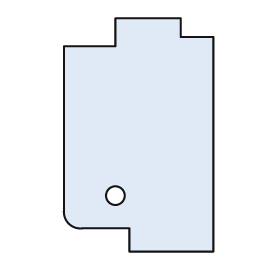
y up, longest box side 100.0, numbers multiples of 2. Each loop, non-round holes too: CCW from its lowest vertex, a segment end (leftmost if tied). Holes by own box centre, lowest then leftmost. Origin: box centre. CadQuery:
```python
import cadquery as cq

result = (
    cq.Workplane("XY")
    .moveTo(-4.0, -50.0)
    .lineTo(32.0, -50.0)
    .lineTo(32.0, 42.0)
    .lineTo(18.0, 42.0)
    .lineTo(18.0, 50.0)
    .lineTo(-10.0, 50.0)
    .lineTo(-10.0, 38.0)
    .lineTo(-32.0, 38.0)
    .lineTo(-32.0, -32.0)
    .threePointArc((-30.0, -38.0), (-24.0, -40.0))
    .lineTo(-4.0, -40.0)
    .close()
    .moveTo(-10.0, -26.0)
    .circle(4.0)
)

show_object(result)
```